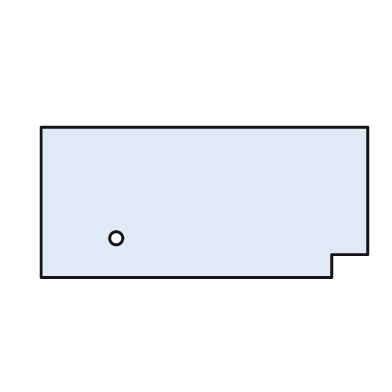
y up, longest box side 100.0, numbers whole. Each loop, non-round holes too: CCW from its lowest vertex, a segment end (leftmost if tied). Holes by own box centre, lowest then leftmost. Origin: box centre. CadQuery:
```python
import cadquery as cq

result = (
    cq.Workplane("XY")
    .moveTo(-50.0, -23.0)
    .lineTo(39.0, -23.0)
    .lineTo(39.0, -16.0)
    .lineTo(50.0, -16.0)
    .lineTo(50.0, 23.0)
    .lineTo(-50.0, 23.0)
    .close()
    .moveTo(-27.0, -11.0)
    .circle(2.0)
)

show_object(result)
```